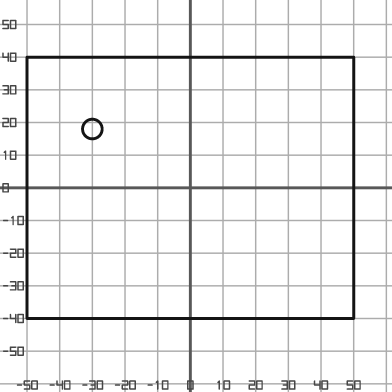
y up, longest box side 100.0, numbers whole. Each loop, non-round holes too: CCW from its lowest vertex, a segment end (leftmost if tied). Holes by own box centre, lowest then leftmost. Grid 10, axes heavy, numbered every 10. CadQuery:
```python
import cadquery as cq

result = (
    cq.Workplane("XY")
    .moveTo(-50.0, -40.0)
    .lineTo(50.0, -40.0)
    .lineTo(50.0, 40.0)
    .lineTo(-50.0, 40.0)
    .close()
    .moveTo(-30.0, 18.0)
    .circle(3.0)
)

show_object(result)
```